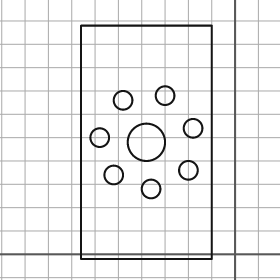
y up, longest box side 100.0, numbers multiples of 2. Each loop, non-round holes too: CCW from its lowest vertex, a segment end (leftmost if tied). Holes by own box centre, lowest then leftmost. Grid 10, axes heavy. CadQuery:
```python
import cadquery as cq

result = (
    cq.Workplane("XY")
    .moveTo(-66.0, -2.0)
    .lineTo(-10.0, -2.0)
    .lineTo(-10.0, 98.0)
    .lineTo(-66.0, 98.0)
    .close()
    .moveTo(-36.0, 28.0)
    .circle(4.0)
    .moveTo(-52.0, 34.0)
    .circle(4.0)
    .moveTo(-20.0, 36.0)
    .circle(4.0)
    .moveTo(-38.0, 48.0)
    .circle(8.0)
    .moveTo(-58.0, 50.0)
    .circle(4.0)
    .moveTo(-18.0, 54.0)
    .circle(4.0)
    .moveTo(-48.0, 66.0)
    .circle(4.0)
    .moveTo(-30.0, 68.0)
    .circle(4.0)
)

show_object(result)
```